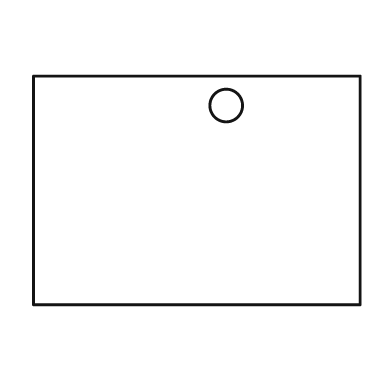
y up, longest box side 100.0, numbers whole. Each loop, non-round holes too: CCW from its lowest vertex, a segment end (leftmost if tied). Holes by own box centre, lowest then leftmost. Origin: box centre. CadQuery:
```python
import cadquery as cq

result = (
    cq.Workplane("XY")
    .moveTo(-50.0, -35.0)
    .lineTo(50.0, -35.0)
    .lineTo(50.0, 35.0)
    .lineTo(-50.0, 35.0)
    .close()
    .moveTo(9.0, 26.0)
    .circle(5.0)
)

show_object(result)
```